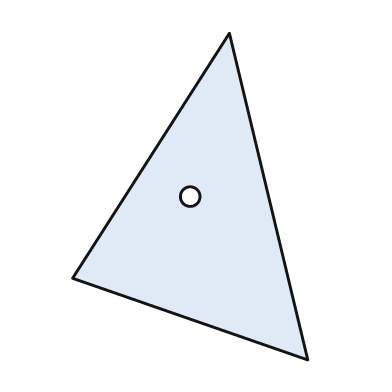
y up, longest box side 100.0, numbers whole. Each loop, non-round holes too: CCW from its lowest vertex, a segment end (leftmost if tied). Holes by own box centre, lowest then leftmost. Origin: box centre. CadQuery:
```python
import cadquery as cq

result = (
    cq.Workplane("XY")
    .moveTo(36.0, -50.0)
    .lineTo(12.0, 50.0)
    .lineTo(-36.0, -25.0)
    .close()
    .moveTo(0.0, 0.0)
    .circle(3.0)
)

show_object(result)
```